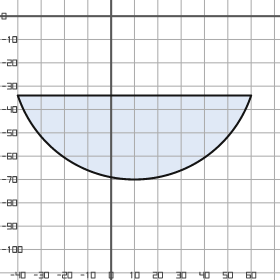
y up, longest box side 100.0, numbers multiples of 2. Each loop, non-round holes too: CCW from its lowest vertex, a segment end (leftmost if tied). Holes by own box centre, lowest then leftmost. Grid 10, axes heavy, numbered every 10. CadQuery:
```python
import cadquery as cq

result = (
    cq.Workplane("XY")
    .moveTo(-40.0, -34.0)
    .threePointArc((10.0, -70.0), (60.0, -34.0))
    .close()
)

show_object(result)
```